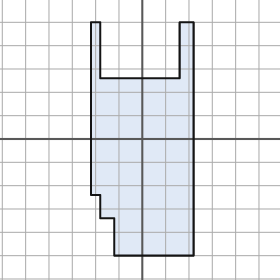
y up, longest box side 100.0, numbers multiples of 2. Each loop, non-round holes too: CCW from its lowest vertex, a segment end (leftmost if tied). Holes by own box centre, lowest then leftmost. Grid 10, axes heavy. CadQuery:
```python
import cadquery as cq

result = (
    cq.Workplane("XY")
    .moveTo(-12.0, -50.0)
    .lineTo(22.0, -50.0)
    .lineTo(22.0, 50.0)
    .lineTo(16.0, 50.0)
    .lineTo(16.0, 26.0)
    .lineTo(-18.0, 26.0)
    .lineTo(-18.0, 50.0)
    .lineTo(-22.0, 50.0)
    .lineTo(-22.0, -24.0)
    .lineTo(-18.0, -24.0)
    .lineTo(-18.0, -34.0)
    .lineTo(-12.0, -34.0)
    .close()
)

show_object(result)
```